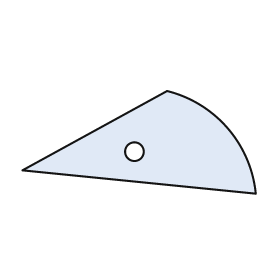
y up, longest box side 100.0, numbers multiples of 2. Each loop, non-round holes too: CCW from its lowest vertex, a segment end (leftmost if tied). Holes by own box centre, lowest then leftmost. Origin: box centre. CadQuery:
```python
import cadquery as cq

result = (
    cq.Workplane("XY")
    .moveTo(50.0, -22.0)
    .threePointArc((38.0, 6.0), (12.0, 22.0))
    .lineTo(-50.0, -12.0)
    .close()
    .moveTo(-2.0, -4.0)
    .circle(4.0)
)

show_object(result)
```